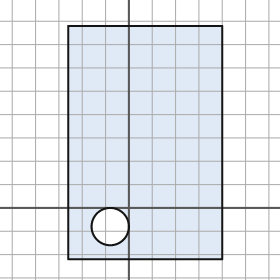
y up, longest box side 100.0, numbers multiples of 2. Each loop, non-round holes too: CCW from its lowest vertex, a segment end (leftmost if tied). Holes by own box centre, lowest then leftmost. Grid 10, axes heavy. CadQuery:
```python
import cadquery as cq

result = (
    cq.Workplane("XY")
    .moveTo(-26.0, -22.0)
    .lineTo(40.0, -22.0)
    .lineTo(40.0, 78.0)
    .lineTo(-26.0, 78.0)
    .close()
    .moveTo(-8.0, -8.0)
    .circle(8.0)
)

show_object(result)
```